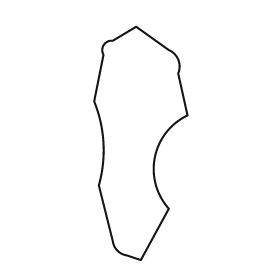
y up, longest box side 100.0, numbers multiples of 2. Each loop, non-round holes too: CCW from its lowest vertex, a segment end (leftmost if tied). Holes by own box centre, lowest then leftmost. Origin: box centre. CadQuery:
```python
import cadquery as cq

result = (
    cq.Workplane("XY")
    .moveTo(0.0, -50.0)
    .lineTo(12.0, -28.0)
    .threePointArc((6.0, -6.0), (20.0, 12.0))
    .lineTo(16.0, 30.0)
    .threePointArc((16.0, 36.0), (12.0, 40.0))
    .lineTo(-2.0, 50.0)
    .lineTo(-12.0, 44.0)
    .threePointArc((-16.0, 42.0), (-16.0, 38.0))
    .lineTo(-20.0, 18.0)
    .threePointArc((-16.0, 0.0), (-18.0, -18.0))
    .lineTo(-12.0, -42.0)
    .threePointArc((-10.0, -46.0), (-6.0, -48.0))
    .close()
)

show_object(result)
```